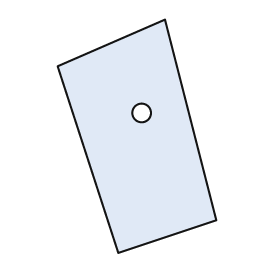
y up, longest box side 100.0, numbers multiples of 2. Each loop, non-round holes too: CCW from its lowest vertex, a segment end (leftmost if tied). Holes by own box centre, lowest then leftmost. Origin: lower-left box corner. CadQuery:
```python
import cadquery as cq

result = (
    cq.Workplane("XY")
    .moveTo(26.0, 0.0)
    .lineTo(68.0, 14.0)
    .lineTo(46.0, 100.0)
    .lineTo(0.0, 80.0)
    .close()
    .moveTo(36.0, 60.0)
    .circle(4.0)
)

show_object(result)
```